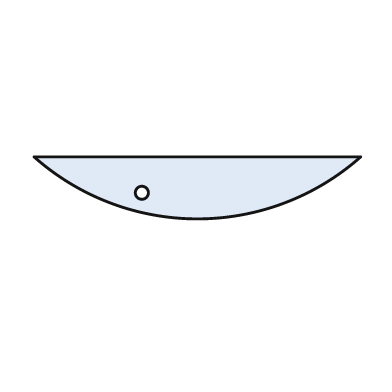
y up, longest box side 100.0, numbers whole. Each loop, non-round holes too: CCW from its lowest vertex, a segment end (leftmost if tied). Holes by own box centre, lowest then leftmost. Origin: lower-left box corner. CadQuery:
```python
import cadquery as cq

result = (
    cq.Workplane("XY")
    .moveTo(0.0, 19.0)
    .threePointArc((50.0, 0.0), (100.0, 19.0))
    .close()
    .moveTo(33.0, 8.0)
    .circle(2.0)
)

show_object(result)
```